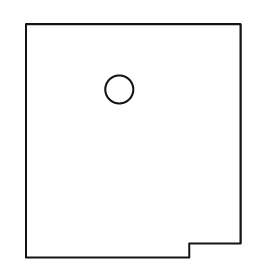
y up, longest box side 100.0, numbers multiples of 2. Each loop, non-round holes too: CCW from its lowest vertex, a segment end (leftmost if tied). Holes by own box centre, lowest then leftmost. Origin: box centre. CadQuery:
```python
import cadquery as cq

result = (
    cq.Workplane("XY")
    .moveTo(-46.0, -50.0)
    .lineTo(24.0, -50.0)
    .lineTo(24.0, -44.0)
    .lineTo(46.0, -44.0)
    .lineTo(46.0, 50.0)
    .lineTo(-46.0, 50.0)
    .close()
    .moveTo(-6.0, 22.0)
    .circle(6.0)
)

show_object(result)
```